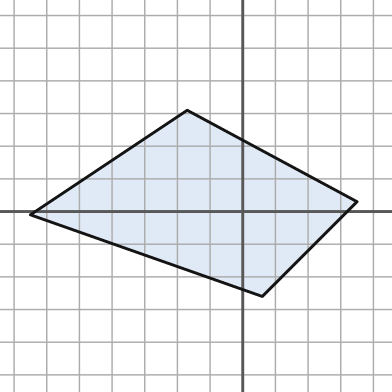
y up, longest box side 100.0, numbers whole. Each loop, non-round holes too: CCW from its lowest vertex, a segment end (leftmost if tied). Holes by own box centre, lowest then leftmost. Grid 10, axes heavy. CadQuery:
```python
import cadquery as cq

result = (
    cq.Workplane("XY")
    .moveTo(6.0, -26.0)
    .lineTo(35.0, 3.0)
    .lineTo(-17.0, 31.0)
    .lineTo(-65.0, -1.0)
    .close()
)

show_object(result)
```